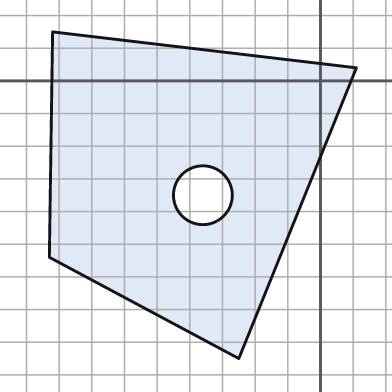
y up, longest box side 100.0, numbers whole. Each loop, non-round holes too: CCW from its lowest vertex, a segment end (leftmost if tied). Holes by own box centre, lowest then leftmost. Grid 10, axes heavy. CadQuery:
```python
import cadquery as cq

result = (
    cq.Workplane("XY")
    .moveTo(-25.0, -85.0)
    .lineTo(11.0, 4.0)
    .lineTo(-82.0, 15.0)
    .lineTo(-83.0, -54.0)
    .close()
    .moveTo(-36.0, -35.0)
    .circle(9.0)
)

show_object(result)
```